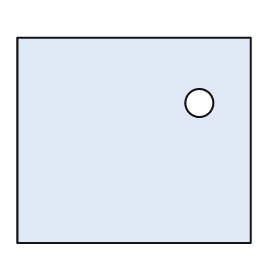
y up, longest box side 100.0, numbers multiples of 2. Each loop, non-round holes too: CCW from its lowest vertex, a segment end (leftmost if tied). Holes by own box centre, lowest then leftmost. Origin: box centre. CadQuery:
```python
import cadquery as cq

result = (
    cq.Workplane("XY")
    .moveTo(-50.0, -44.0)
    .lineTo(50.0, -44.0)
    .lineTo(50.0, 44.0)
    .lineTo(-50.0, 44.0)
    .close()
    .moveTo(28.0, 16.0)
    .circle(6.0)
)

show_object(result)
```